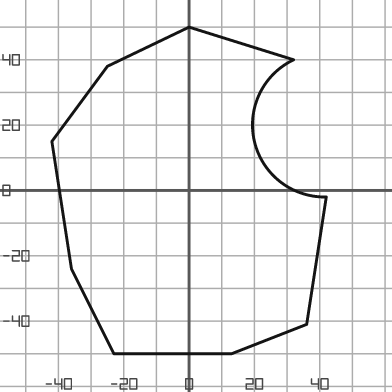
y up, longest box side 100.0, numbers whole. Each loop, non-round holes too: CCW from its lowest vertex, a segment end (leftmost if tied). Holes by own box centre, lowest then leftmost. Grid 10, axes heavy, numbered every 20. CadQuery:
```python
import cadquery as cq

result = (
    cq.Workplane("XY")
    .moveTo(-23.0, -50.0)
    .lineTo(13.0, -50.0)
    .lineTo(36.0, -41.0)
    .lineTo(42.0, -2.0)
    .threePointArc((20.0, 15.0), (32.0, 40.0))
    .lineTo(0.0, 50.0)
    .lineTo(-25.0, 38.0)
    .lineTo(-42.0, 15.0)
    .lineTo(-36.0, -24.0)
    .close()
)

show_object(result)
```